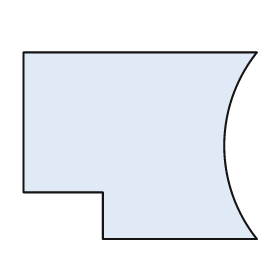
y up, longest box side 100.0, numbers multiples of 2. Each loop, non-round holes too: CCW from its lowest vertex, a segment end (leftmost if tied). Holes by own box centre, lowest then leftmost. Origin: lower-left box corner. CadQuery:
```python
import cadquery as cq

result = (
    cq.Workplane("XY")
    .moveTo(34.0, 0.0)
    .lineTo(100.0, 0.0)
    .threePointArc((86.0, 40.0), (100.0, 80.0))
    .lineTo(0.0, 80.0)
    .lineTo(0.0, 20.0)
    .lineTo(34.0, 20.0)
    .close()
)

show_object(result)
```